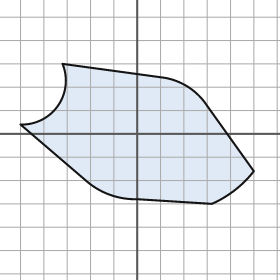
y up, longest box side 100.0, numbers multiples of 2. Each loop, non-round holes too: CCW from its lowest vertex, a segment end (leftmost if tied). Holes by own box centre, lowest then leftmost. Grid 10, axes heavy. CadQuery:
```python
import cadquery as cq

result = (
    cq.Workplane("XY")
    .moveTo(32.0, -30.0)
    .threePointArc((42.0, -24.0), (50.0, -16.0))
    .lineTo(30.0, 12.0)
    .threePointArc((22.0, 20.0), (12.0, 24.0))
    .lineTo(-32.0, 30.0)
    .threePointArc((-34.0, 12.0), (-50.0, 4.0))
    .lineTo(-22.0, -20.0)
    .threePointArc((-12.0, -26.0), (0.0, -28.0))
    .close()
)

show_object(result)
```